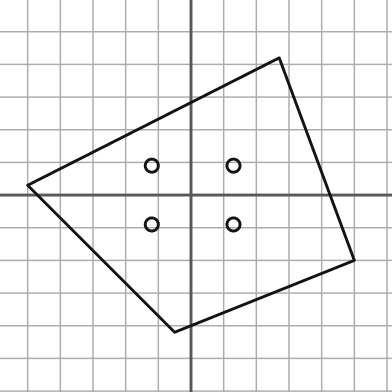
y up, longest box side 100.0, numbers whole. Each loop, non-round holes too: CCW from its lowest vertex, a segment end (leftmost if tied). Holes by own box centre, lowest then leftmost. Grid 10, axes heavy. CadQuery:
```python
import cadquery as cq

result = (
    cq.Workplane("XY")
    .moveTo(-5.0, -42.0)
    .lineTo(50.0, -20.0)
    .lineTo(27.0, 42.0)
    .lineTo(-50.0, 3.0)
    .close()
    .moveTo(-12.0, -9.0)
    .circle(2.0)
    .moveTo(13.0, -9.0)
    .circle(2.0)
    .moveTo(-12.0, 9.0)
    .circle(2.0)
    .moveTo(13.0, 9.0)
    .circle(2.0)
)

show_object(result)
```